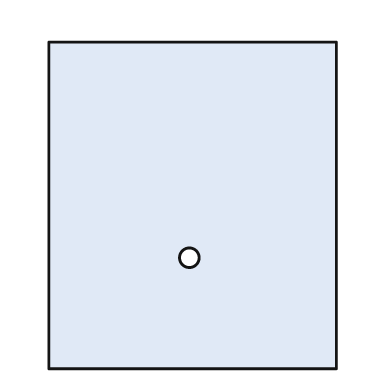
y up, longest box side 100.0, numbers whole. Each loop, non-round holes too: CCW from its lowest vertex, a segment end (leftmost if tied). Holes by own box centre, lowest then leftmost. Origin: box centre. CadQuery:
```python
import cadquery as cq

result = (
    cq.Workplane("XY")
    .moveTo(-44.0, -50.0)
    .lineTo(44.0, -50.0)
    .lineTo(44.0, 50.0)
    .lineTo(-44.0, 50.0)
    .close()
    .moveTo(-1.0, -16.0)
    .circle(3.0)
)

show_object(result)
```